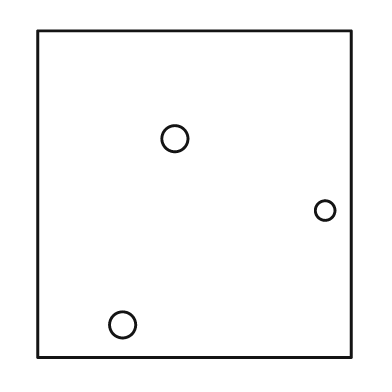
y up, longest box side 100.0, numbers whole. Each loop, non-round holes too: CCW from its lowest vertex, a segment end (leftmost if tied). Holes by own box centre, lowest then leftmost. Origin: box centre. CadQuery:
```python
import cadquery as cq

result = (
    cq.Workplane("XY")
    .moveTo(-48.0, -50.0)
    .lineTo(48.0, -50.0)
    .lineTo(48.0, 50.0)
    .lineTo(-48.0, 50.0)
    .close()
    .moveTo(-22.0, -40.0)
    .circle(4.0)
    .moveTo(40.0, -5.0)
    .circle(3.0)
    .moveTo(-6.0, 17.0)
    .circle(4.0)
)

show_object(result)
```